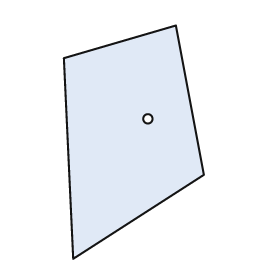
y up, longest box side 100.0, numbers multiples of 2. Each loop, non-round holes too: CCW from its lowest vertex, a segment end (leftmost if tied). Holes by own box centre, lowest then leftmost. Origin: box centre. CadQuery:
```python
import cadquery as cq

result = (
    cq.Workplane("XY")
    .moveTo(-26.0, -50.0)
    .lineTo(30.0, -14.0)
    .lineTo(18.0, 50.0)
    .lineTo(-30.0, 36.0)
    .close()
    .moveTo(6.0, 10.0)
    .circle(2.0)
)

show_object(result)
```